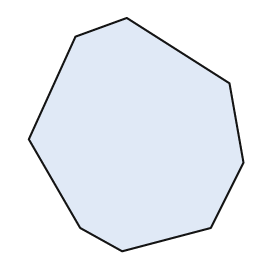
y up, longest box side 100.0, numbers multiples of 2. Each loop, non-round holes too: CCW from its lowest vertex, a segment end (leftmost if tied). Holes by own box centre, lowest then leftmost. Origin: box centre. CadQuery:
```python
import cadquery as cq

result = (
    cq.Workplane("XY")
    .moveTo(-6.0, -50.0)
    .lineTo(32.0, -40.0)
    .lineTo(46.0, -12.0)
    .lineTo(40.0, 22.0)
    .lineTo(-4.0, 50.0)
    .lineTo(-26.0, 42.0)
    .lineTo(-46.0, -2.0)
    .lineTo(-24.0, -40.0)
    .close()
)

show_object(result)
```